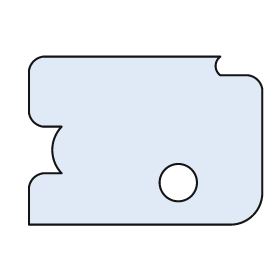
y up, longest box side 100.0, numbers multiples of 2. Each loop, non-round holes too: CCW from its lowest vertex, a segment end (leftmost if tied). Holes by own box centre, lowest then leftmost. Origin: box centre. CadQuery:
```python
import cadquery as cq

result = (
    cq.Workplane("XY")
    .moveTo(-50.0, -36.0)
    .lineTo(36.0, -36.0)
    .threePointArc((46.0, -32.0), (50.0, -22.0))
    .lineTo(50.0, 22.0)
    .threePointArc((48.0, 26.0), (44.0, 28.0))
    .lineTo(32.0, 28.0)
    .threePointArc((30.0, 32.0), (32.0, 36.0))
    .lineTo(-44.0, 36.0)
    .threePointArc((-48.0, 34.0), (-50.0, 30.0))
    .lineTo(-50.0, 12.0)
    .threePointArc((-48.0, 8.0), (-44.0, 6.0))
    .lineTo(-36.0, 6.0)
    .threePointArc((-40.0, -4.0), (-36.0, -14.0))
    .lineTo(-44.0, -14.0)
    .threePointArc((-48.0, -16.0), (-50.0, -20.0))
    .close()
    .moveTo(14.0, -18.0)
    .circle(8.0)
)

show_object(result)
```